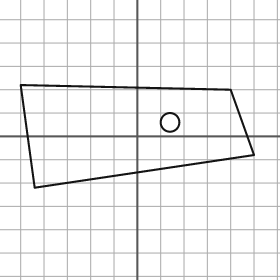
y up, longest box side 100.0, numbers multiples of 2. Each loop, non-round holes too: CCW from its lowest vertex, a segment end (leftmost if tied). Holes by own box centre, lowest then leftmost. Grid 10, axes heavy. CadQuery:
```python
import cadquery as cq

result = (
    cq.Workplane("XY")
    .moveTo(-44.0, -22.0)
    .lineTo(50.0, -8.0)
    .lineTo(40.0, 20.0)
    .lineTo(-50.0, 22.0)
    .close()
    .moveTo(14.0, 6.0)
    .circle(4.0)
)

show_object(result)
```